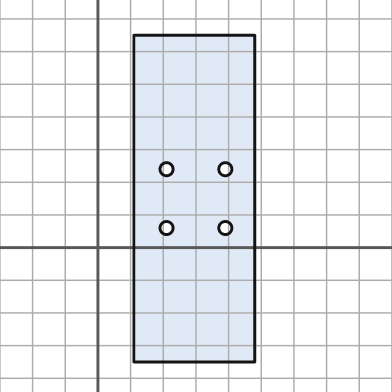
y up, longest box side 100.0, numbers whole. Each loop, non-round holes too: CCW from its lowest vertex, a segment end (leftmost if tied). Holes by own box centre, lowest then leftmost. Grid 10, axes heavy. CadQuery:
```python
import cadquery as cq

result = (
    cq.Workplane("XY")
    .moveTo(11.0, -35.0)
    .lineTo(48.0, -35.0)
    .lineTo(48.0, 65.0)
    .lineTo(11.0, 65.0)
    .close()
    .moveTo(21.0, 6.0)
    .circle(2.0)
    .moveTo(39.0, 6.0)
    .circle(2.0)
    .moveTo(21.0, 24.0)
    .circle(2.0)
    .moveTo(39.0, 24.0)
    .circle(2.0)
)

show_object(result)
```